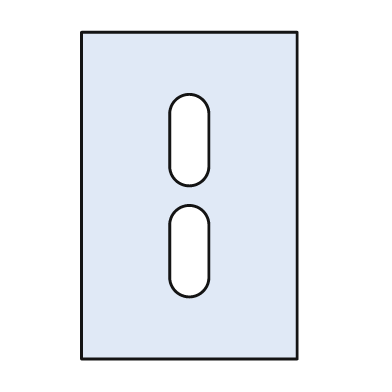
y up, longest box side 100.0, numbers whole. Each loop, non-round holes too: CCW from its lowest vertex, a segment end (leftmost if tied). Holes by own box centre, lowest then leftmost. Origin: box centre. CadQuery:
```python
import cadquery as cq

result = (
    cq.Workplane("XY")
    .moveTo(-33.0, -50.0)
    .lineTo(33.0, -50.0)
    .lineTo(33.0, 50.0)
    .lineTo(-33.0, 50.0)
    .close()
    .moveTo(-6.0, -25.0)
    .threePointArc((0.0, -31.0), (6.0, -25.0))
    .lineTo(6.0, -9.0)
    .threePointArc((0.0, -3.0), (-6.0, -9.0))
    .close()
    .moveTo(-6.0, 9.0)
    .threePointArc((0.0, 3.0), (6.0, 9.0))
    .lineTo(6.0, 25.0)
    .threePointArc((0.0, 31.0), (-6.0, 25.0))
    .close()
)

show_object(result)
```